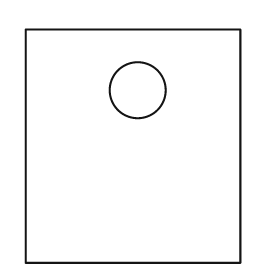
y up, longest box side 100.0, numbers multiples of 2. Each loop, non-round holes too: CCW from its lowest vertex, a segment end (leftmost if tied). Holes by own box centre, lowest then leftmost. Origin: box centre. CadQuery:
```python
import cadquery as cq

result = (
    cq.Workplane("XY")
    .moveTo(-46.0, -50.0)
    .lineTo(46.0, -50.0)
    .lineTo(46.0, 50.0)
    .lineTo(-46.0, 50.0)
    .close()
    .moveTo(2.0, 24.0)
    .circle(12.0)
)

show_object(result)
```